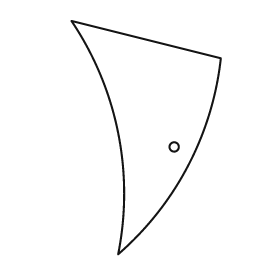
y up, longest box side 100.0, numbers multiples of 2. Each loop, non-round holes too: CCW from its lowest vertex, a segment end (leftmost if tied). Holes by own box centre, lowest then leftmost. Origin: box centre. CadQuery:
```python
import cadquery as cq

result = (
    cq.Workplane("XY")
    .moveTo(-12.0, -50.0)
    .threePointArc((18.0, -12.0), (32.0, 34.0))
    .lineTo(-32.0, 50.0)
    .threePointArc((-12.0, 2.0), (-12.0, -50.0))
    .close()
    .moveTo(12.0, -4.0)
    .circle(2.0)
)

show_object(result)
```